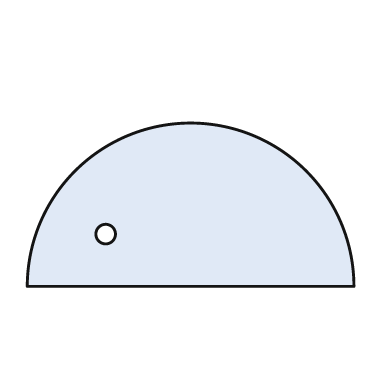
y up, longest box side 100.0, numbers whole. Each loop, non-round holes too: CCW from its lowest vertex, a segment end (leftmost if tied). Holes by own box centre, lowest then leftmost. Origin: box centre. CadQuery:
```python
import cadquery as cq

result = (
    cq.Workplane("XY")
    .moveTo(-50.0, -25.0)
    .lineTo(50.0, -25.0)
    .threePointArc((0.0, 25.0), (-50.0, -25.0))
    .close()
    .moveTo(-26.0, -9.0)
    .circle(3.0)
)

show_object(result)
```